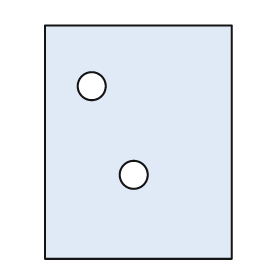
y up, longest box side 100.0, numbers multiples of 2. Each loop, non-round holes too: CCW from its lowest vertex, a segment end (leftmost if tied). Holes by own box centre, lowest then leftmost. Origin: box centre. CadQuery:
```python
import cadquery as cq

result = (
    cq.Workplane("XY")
    .moveTo(-40.0, -50.0)
    .lineTo(40.0, -50.0)
    .lineTo(40.0, 50.0)
    .lineTo(-40.0, 50.0)
    .close()
    .moveTo(-2.0, -14.0)
    .circle(6.0)
    .moveTo(-20.0, 24.0)
    .circle(6.0)
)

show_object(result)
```